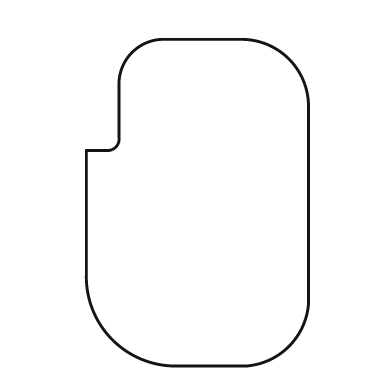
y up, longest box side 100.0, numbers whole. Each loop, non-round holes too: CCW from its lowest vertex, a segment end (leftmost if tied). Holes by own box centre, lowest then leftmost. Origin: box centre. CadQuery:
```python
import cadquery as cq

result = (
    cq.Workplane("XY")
    .moveTo(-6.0, -50.0)
    .lineTo(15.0, -50.0)
    .threePointArc((28.0, -44.0), (34.0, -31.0))
    .lineTo(34.0, 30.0)
    .threePointArc((28.0, 44.0), (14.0, 50.0))
    .lineTo(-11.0, 50.0)
    .threePointArc((-20.0, 46.0), (-24.0, 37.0))
    .lineTo(-24.0, 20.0)
    .threePointArc((-25.0, 17.0), (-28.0, 16.0))
    .lineTo(-34.0, 16.0)
    .lineTo(-34.0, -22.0)
    .threePointArc((-26.0, -42.0), (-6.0, -50.0))
    .close()
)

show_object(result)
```